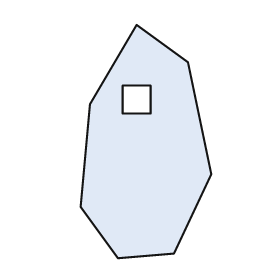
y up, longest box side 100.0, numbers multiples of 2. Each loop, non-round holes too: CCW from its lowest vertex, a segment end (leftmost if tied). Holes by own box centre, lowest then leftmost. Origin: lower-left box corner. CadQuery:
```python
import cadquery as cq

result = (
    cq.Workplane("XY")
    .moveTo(16.0, 0.0)
    .lineTo(40.0, 2.0)
    .lineTo(56.0, 36.0)
    .lineTo(46.0, 84.0)
    .lineTo(24.0, 100.0)
    .lineTo(4.0, 66.0)
    .lineTo(0.0, 22.0)
    .close()
    .moveTo(18.0, 62.0)
    .lineTo(30.0, 62.0)
    .lineTo(30.0, 74.0)
    .lineTo(18.0, 74.0)
    .close()
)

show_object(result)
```